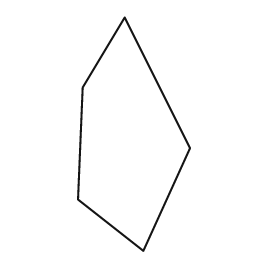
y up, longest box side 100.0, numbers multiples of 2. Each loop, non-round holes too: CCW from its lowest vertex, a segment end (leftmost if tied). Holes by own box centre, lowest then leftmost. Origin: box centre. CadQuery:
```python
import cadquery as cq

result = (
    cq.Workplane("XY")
    .moveTo(4.0, -50.0)
    .lineTo(24.0, -6.0)
    .lineTo(-4.0, 50.0)
    .lineTo(-22.0, 20.0)
    .lineTo(-24.0, -28.0)
    .close()
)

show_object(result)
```